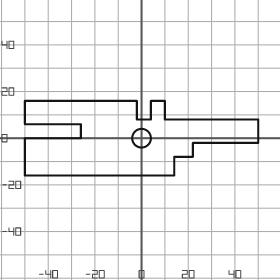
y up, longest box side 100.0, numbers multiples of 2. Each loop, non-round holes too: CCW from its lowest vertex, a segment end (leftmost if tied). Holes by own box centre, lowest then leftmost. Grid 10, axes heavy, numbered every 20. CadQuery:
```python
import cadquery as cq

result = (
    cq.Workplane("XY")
    .moveTo(-50.0, -16.0)
    .lineTo(14.0, -16.0)
    .lineTo(14.0, -8.0)
    .lineTo(22.0, -8.0)
    .lineTo(22.0, -2.0)
    .lineTo(50.0, -2.0)
    .lineTo(50.0, 8.0)
    .lineTo(10.0, 8.0)
    .lineTo(10.0, 16.0)
    .lineTo(4.0, 16.0)
    .lineTo(4.0, 8.0)
    .lineTo(-2.0, 8.0)
    .lineTo(-2.0, 16.0)
    .lineTo(-50.0, 16.0)
    .lineTo(-50.0, 6.0)
    .lineTo(-26.0, 6.0)
    .lineTo(-26.0, 0.0)
    .lineTo(-50.0, 0.0)
    .close()
    .moveTo(0.0, 0.0)
    .circle(4.0)
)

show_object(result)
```